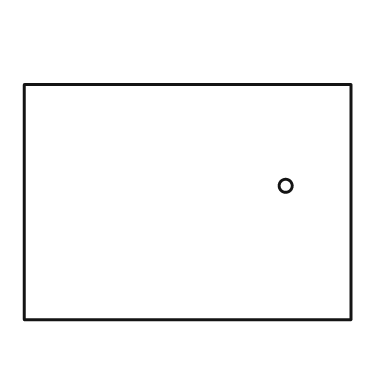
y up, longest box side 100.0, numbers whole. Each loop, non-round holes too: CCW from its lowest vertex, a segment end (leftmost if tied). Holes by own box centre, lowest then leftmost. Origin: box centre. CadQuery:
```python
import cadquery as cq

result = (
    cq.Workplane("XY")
    .moveTo(-50.0, -36.0)
    .lineTo(50.0, -36.0)
    .lineTo(50.0, 36.0)
    .lineTo(-50.0, 36.0)
    .close()
    .moveTo(30.0, 5.0)
    .circle(2.0)
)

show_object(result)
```